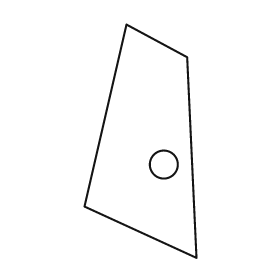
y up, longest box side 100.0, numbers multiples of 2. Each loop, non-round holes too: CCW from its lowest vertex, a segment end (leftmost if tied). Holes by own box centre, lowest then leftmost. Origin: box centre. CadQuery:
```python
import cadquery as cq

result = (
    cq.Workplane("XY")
    .moveTo(24.0, -50.0)
    .lineTo(20.0, 36.0)
    .lineTo(-6.0, 50.0)
    .lineTo(-24.0, -28.0)
    .close()
    .moveTo(10.0, -10.0)
    .circle(6.0)
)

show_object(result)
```